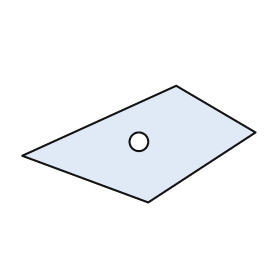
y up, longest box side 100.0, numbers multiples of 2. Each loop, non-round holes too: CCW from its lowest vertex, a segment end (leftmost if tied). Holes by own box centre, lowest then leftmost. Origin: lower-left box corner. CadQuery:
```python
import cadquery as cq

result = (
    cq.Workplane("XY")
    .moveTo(54.0, 0.0)
    .lineTo(100.0, 30.0)
    .lineTo(66.0, 50.0)
    .lineTo(0.0, 20.0)
    .close()
    .moveTo(50.0, 26.0)
    .circle(4.0)
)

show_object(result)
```